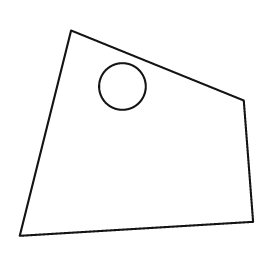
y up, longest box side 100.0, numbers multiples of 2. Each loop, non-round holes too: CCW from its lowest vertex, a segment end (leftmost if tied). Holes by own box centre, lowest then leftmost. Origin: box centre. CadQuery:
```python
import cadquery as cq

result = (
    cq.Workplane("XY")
    .moveTo(-50.0, -44.0)
    .lineTo(50.0, -38.0)
    .lineTo(46.0, 14.0)
    .lineTo(-28.0, 44.0)
    .close()
    .moveTo(-6.0, 20.0)
    .circle(10.0)
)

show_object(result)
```